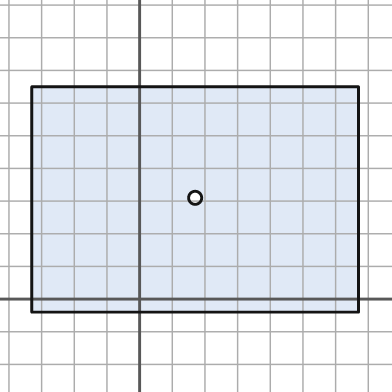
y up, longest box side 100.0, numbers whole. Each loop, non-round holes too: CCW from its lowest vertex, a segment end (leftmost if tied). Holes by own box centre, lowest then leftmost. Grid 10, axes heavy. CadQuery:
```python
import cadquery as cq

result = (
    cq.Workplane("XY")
    .moveTo(-33.0, -4.0)
    .lineTo(67.0, -4.0)
    .lineTo(67.0, 65.0)
    .lineTo(-33.0, 65.0)
    .close()
    .moveTo(17.0, 31.0)
    .circle(2.0)
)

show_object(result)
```